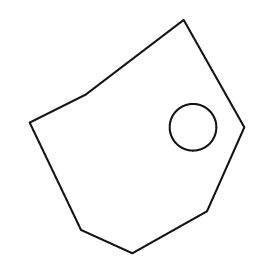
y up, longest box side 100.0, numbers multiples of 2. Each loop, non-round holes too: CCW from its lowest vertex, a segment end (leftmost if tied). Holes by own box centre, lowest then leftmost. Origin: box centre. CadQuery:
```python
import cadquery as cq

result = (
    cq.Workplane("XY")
    .moveTo(-2.0, -50.0)
    .lineTo(30.0, -32.0)
    .lineTo(46.0, 4.0)
    .lineTo(20.0, 50.0)
    .lineTo(-22.0, 18.0)
    .lineTo(-46.0, 6.0)
    .lineTo(-24.0, -40.0)
    .close()
    .moveTo(24.0, 4.0)
    .circle(10.0)
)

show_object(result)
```